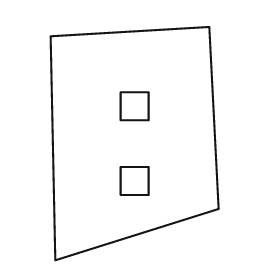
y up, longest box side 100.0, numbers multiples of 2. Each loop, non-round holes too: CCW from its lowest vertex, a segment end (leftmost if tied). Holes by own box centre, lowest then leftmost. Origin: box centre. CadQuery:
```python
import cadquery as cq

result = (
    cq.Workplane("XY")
    .moveTo(-34.0, -50.0)
    .lineTo(36.0, -28.0)
    .lineTo(32.0, 50.0)
    .lineTo(-36.0, 46.0)
    .close()
    .moveTo(-6.0, -22.0)
    .lineTo(6.0, -22.0)
    .lineTo(6.0, -10.0)
    .lineTo(-6.0, -10.0)
    .close()
    .moveTo(-6.0, 10.0)
    .lineTo(6.0, 10.0)
    .lineTo(6.0, 22.0)
    .lineTo(-6.0, 22.0)
    .close()
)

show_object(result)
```